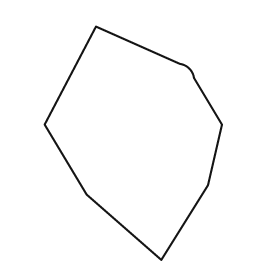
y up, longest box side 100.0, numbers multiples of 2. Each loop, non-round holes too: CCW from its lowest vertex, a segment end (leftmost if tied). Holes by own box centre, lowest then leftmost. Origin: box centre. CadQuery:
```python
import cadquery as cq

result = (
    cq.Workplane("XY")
    .moveTo(12.0, -50.0)
    .lineTo(32.0, -18.0)
    .lineTo(38.0, 8.0)
    .lineTo(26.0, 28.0)
    .threePointArc((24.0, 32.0), (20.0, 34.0))
    .lineTo(-16.0, 50.0)
    .lineTo(-38.0, 8.0)
    .lineTo(-20.0, -22.0)
    .close()
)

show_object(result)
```